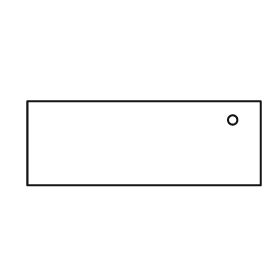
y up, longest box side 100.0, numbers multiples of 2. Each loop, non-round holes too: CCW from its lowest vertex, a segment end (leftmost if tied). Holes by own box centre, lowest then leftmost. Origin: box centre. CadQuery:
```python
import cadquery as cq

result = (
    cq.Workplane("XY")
    .moveTo(-50.0, -18.0)
    .lineTo(50.0, -18.0)
    .lineTo(50.0, 18.0)
    .lineTo(-50.0, 18.0)
    .close()
    .moveTo(38.0, 10.0)
    .circle(2.0)
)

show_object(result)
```